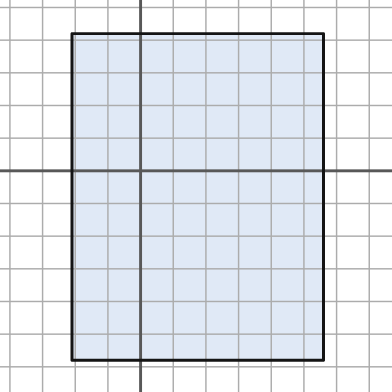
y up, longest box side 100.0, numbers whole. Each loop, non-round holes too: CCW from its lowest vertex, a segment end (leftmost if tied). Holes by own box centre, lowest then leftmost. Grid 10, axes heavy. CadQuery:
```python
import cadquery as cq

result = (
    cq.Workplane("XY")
    .moveTo(-21.0, -58.0)
    .lineTo(56.0, -58.0)
    .lineTo(56.0, 42.0)
    .lineTo(-21.0, 42.0)
    .close()
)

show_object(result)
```